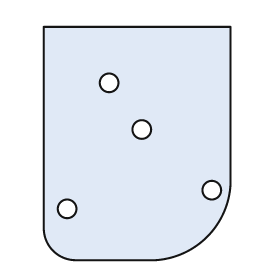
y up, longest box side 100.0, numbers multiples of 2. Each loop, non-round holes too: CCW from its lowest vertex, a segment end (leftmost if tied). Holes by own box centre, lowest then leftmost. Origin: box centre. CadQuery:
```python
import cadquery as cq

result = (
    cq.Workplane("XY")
    .moveTo(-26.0, -50.0)
    .lineTo(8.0, -50.0)
    .threePointArc((30.0, -40.0), (40.0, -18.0))
    .lineTo(40.0, 50.0)
    .lineTo(-40.0, 50.0)
    .lineTo(-40.0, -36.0)
    .threePointArc((-36.0, -46.0), (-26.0, -50.0))
    .close()
    .moveTo(-30.0, -28.0)
    .circle(4.0)
    .moveTo(32.0, -20.0)
    .circle(4.0)
    .moveTo(2.0, 6.0)
    .circle(4.0)
    .moveTo(-12.0, 26.0)
    .circle(4.0)
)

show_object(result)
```